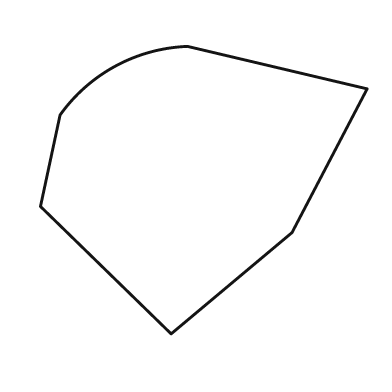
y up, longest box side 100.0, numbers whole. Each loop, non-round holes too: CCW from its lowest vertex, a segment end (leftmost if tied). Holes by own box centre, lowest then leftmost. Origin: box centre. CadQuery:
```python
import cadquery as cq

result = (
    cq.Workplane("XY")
    .moveTo(-10.0, -44.0)
    .lineTo(27.0, -13.0)
    .lineTo(50.0, 31.0)
    .lineTo(-5.0, 44.0)
    .threePointArc((-27.0, 38.0), (-44.0, 23.0))
    .lineTo(-50.0, -5.0)
    .close()
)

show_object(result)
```